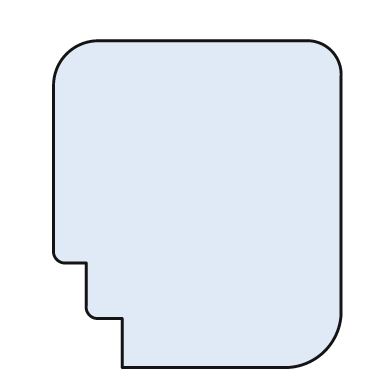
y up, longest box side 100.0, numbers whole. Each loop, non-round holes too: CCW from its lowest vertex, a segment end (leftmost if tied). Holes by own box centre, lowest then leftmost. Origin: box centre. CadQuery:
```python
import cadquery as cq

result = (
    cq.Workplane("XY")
    .moveTo(-23.0, -50.0)
    .lineTo(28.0, -50.0)
    .threePointArc((39.0, -45.0), (44.0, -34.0))
    .lineTo(44.0, 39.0)
    .threePointArc((41.0, 47.0), (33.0, 50.0))
    .lineTo(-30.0, 50.0)
    .threePointArc((-40.0, 46.0), (-44.0, 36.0))
    .lineTo(-44.0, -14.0)
    .threePointArc((-43.0, -17.0), (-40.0, -18.0))
    .lineTo(-34.0, -18.0)
    .lineTo(-34.0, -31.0)
    .threePointArc((-33.0, -34.0), (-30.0, -35.0))
    .lineTo(-23.0, -35.0)
    .close()
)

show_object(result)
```